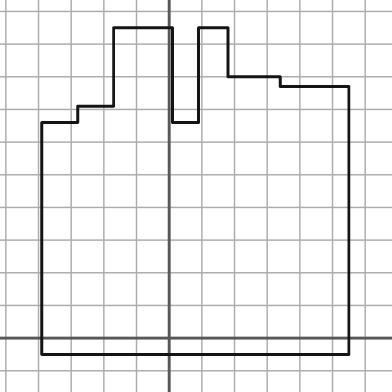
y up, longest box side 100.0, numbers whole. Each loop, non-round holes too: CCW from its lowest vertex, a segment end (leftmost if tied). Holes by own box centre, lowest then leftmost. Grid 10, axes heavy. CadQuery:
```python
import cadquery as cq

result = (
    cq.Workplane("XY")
    .moveTo(-39.0, -5.0)
    .lineTo(55.0, -5.0)
    .lineTo(55.0, 77.0)
    .lineTo(34.0, 77.0)
    .lineTo(34.0, 80.0)
    .lineTo(18.0, 80.0)
    .lineTo(18.0, 95.0)
    .lineTo(9.0, 95.0)
    .lineTo(9.0, 66.0)
    .lineTo(1.0, 66.0)
    .lineTo(1.0, 95.0)
    .lineTo(-17.0, 95.0)
    .lineTo(-17.0, 71.0)
    .lineTo(-28.0, 71.0)
    .lineTo(-28.0, 66.0)
    .lineTo(-39.0, 66.0)
    .close()
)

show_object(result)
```